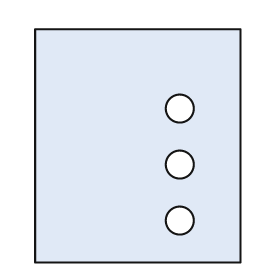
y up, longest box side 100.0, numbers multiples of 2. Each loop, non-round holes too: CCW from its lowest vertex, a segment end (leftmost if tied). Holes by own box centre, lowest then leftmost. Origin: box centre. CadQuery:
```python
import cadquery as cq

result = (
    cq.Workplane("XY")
    .moveTo(-44.0, -50.0)
    .lineTo(44.0, -50.0)
    .lineTo(44.0, 50.0)
    .lineTo(-44.0, 50.0)
    .close()
    .moveTo(18.0, -32.0)
    .circle(6.0)
    .moveTo(18.0, -8.0)
    .circle(6.0)
    .moveTo(18.0, 16.0)
    .circle(6.0)
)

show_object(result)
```